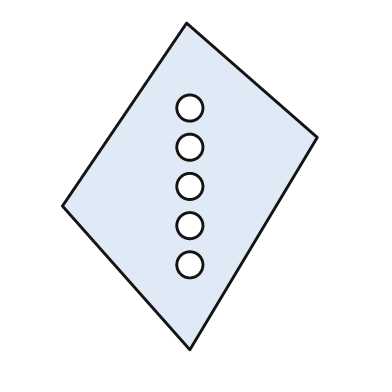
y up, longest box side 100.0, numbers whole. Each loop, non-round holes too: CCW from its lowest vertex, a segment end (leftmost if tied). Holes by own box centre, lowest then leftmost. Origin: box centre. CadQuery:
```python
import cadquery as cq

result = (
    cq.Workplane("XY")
    .moveTo(0.0, -50.0)
    .lineTo(39.0, 15.0)
    .lineTo(-1.0, 50.0)
    .lineTo(-39.0, -6.0)
    .close()
    .moveTo(0.0, -24.0)
    .circle(4.0)
    .moveTo(0.0, -12.0)
    .circle(4.0)
    .moveTo(0.0, 0.0)
    .circle(4.0)
    .moveTo(0.0, 12.0)
    .circle(4.0)
    .moveTo(0.0, 24.0)
    .circle(4.0)
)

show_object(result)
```